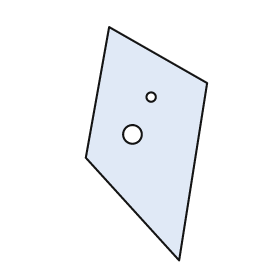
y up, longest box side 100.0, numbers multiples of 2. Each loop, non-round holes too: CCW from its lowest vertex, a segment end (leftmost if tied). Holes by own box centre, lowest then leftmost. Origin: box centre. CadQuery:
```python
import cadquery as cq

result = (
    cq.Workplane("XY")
    .moveTo(14.0, -50.0)
    .lineTo(26.0, 26.0)
    .lineTo(-16.0, 50.0)
    .lineTo(-26.0, -6.0)
    .close()
    .moveTo(-6.0, 4.0)
    .circle(4.0)
    .moveTo(2.0, 20.0)
    .circle(2.0)
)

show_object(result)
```